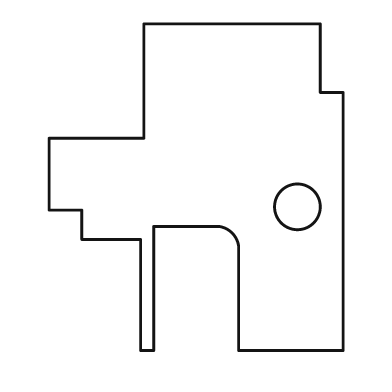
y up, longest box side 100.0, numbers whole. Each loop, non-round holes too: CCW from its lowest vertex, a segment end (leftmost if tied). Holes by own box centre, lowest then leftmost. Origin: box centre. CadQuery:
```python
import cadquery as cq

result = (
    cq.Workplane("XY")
    .moveTo(-17.0, -50.0)
    .lineTo(-13.0, -50.0)
    .lineTo(-13.0, -12.0)
    .lineTo(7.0, -12.0)
    .threePointArc((11.0, -14.0), (13.0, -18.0))
    .lineTo(13.0, -50.0)
    .lineTo(45.0, -50.0)
    .lineTo(45.0, 29.0)
    .lineTo(38.0, 29.0)
    .lineTo(38.0, 50.0)
    .lineTo(-16.0, 50.0)
    .lineTo(-16.0, 15.0)
    .lineTo(-45.0, 15.0)
    .lineTo(-45.0, -7.0)
    .lineTo(-35.0, -7.0)
    .lineTo(-35.0, -16.0)
    .lineTo(-17.0, -16.0)
    .close()
    .moveTo(31.0, -6.0)
    .circle(7.0)
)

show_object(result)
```